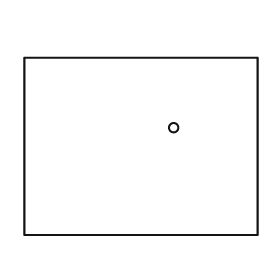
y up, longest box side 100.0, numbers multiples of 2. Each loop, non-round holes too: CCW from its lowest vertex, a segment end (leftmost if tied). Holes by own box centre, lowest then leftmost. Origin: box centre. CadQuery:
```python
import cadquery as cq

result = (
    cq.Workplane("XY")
    .moveTo(-50.0, -38.0)
    .lineTo(50.0, -38.0)
    .lineTo(50.0, 38.0)
    .lineTo(-50.0, 38.0)
    .close()
    .moveTo(14.0, 8.0)
    .circle(2.0)
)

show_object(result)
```